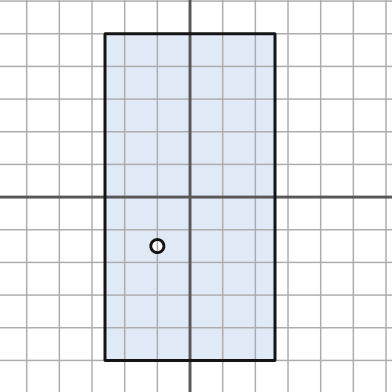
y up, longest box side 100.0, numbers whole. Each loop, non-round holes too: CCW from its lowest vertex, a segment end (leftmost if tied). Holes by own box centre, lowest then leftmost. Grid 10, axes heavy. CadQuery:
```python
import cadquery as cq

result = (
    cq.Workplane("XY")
    .moveTo(-26.0, -50.0)
    .lineTo(26.0, -50.0)
    .lineTo(26.0, 50.0)
    .lineTo(-26.0, 50.0)
    .close()
    .moveTo(-10.0, -15.0)
    .circle(2.0)
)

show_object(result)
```